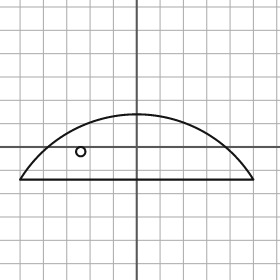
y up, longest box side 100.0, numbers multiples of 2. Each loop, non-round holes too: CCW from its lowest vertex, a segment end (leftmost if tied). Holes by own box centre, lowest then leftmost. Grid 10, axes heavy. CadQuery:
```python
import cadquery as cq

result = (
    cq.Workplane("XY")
    .moveTo(-50.0, -14.0)
    .lineTo(50.0, -14.0)
    .threePointArc((0.0, 14.0), (-50.0, -14.0))
    .close()
    .moveTo(-24.0, -2.0)
    .circle(2.0)
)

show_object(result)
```